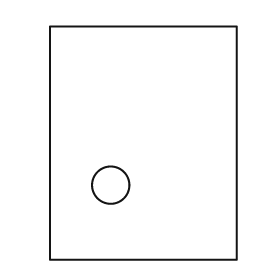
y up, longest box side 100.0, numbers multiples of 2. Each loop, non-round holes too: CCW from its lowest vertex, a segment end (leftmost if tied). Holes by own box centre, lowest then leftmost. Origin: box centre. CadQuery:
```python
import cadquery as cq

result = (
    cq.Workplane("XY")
    .moveTo(-40.0, -50.0)
    .lineTo(40.0, -50.0)
    .lineTo(40.0, 50.0)
    .lineTo(-40.0, 50.0)
    .close()
    .moveTo(-14.0, -18.0)
    .circle(8.0)
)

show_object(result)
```